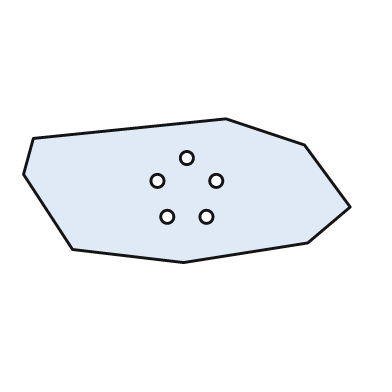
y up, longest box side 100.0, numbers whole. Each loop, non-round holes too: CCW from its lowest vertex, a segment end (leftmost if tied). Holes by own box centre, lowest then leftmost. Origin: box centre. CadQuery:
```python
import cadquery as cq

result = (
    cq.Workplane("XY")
    .moveTo(-1.0, -22.0)
    .lineTo(37.0, -16.0)
    .lineTo(50.0, -5.0)
    .lineTo(36.0, 14.0)
    .lineTo(12.0, 22.0)
    .lineTo(-47.0, 16.0)
    .lineTo(-50.0, 5.0)
    .lineTo(-35.0, -18.0)
    .close()
    .moveTo(-6.0, -8.0)
    .circle(2.0)
    .moveTo(6.0, -8.0)
    .circle(2.0)
    .moveTo(-9.0, 3.0)
    .circle(2.0)
    .moveTo(9.0, 3.0)
    .circle(2.0)
    .moveTo(0.0, 10.0)
    .circle(2.0)
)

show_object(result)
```